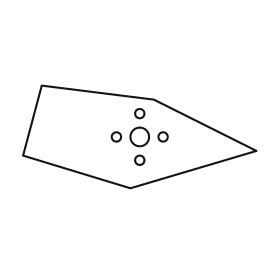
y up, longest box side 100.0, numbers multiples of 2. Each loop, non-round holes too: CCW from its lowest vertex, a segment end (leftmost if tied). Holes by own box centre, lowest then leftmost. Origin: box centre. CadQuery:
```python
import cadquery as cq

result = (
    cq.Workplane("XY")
    .moveTo(-4.0, -22.0)
    .lineTo(50.0, -6.0)
    .lineTo(6.0, 16.0)
    .lineTo(-42.0, 22.0)
    .lineTo(-50.0, -8.0)
    .close()
    .moveTo(0.0, -10.0)
    .circle(2.0)
    .moveTo(-10.0, 0.0)
    .circle(2.0)
    .moveTo(0.0, 0.0)
    .circle(4.0)
    .moveTo(10.0, 0.0)
    .circle(2.0)
    .moveTo(0.0, 10.0)
    .circle(2.0)
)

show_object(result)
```